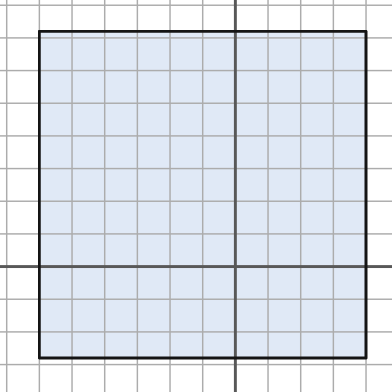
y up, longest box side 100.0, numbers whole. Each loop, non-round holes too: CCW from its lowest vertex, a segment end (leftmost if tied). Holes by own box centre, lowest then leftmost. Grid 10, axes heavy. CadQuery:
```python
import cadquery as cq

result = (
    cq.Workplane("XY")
    .moveTo(-60.0, -28.0)
    .lineTo(40.0, -28.0)
    .lineTo(40.0, 72.0)
    .lineTo(-60.0, 72.0)
    .close()
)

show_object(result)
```